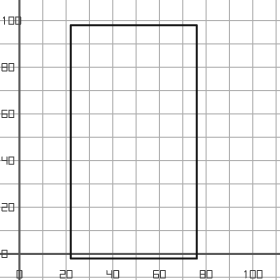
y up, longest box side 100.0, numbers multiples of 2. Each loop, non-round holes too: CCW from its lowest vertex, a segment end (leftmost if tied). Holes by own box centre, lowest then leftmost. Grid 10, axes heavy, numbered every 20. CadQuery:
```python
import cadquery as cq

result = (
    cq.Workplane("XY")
    .moveTo(22.0, -2.0)
    .lineTo(76.0, -2.0)
    .lineTo(76.0, 98.0)
    .lineTo(22.0, 98.0)
    .close()
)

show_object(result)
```